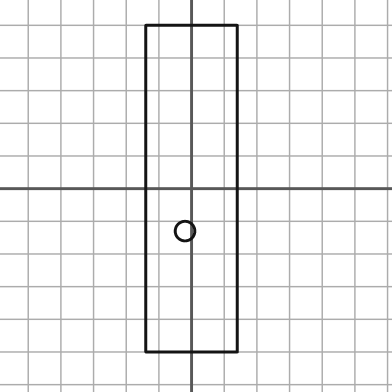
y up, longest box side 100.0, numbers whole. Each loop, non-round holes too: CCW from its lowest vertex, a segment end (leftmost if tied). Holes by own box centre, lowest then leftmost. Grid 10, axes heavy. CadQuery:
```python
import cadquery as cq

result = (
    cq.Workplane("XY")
    .moveTo(-14.0, -50.0)
    .lineTo(14.0, -50.0)
    .lineTo(14.0, 50.0)
    .lineTo(-14.0, 50.0)
    .close()
    .moveTo(-2.0, -13.0)
    .circle(3.0)
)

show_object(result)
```